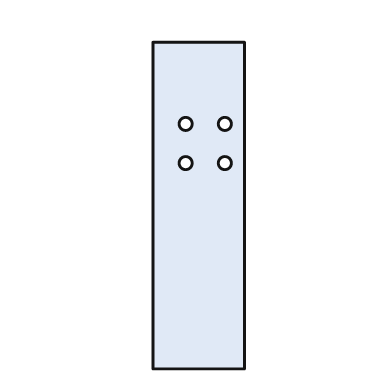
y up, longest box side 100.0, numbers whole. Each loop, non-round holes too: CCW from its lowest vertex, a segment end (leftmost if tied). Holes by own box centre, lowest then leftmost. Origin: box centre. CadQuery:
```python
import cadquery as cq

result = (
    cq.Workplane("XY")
    .moveTo(-14.0, -50.0)
    .lineTo(14.0, -50.0)
    .lineTo(14.0, 50.0)
    .lineTo(-14.0, 50.0)
    .close()
    .moveTo(-4.0, 13.0)
    .circle(2.0)
    .moveTo(8.0, 13.0)
    .circle(2.0)
    .moveTo(-4.0, 25.0)
    .circle(2.0)
    .moveTo(8.0, 25.0)
    .circle(2.0)
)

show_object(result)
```